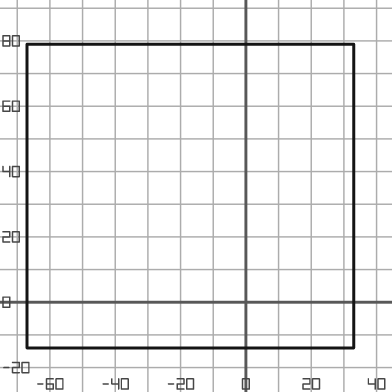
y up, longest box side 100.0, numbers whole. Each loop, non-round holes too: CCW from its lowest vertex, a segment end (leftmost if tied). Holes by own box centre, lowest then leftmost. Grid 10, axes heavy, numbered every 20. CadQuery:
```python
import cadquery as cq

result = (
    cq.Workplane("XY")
    .moveTo(-67.0, -14.0)
    .lineTo(33.0, -14.0)
    .lineTo(33.0, 79.0)
    .lineTo(-67.0, 79.0)
    .close()
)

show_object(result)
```